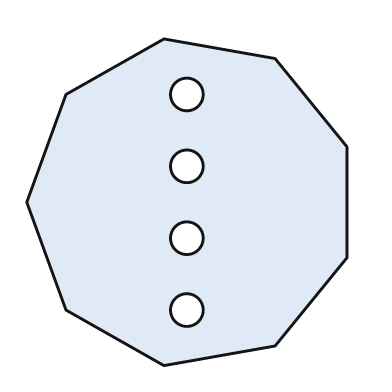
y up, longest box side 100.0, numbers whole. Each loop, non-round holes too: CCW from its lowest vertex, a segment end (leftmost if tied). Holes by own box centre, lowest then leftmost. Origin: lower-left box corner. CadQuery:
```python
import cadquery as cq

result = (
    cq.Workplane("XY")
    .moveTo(42.0, 0.0)
    .lineTo(76.0, 6.0)
    .lineTo(98.0, 33.0)
    .lineTo(98.0, 67.0)
    .lineTo(76.0, 94.0)
    .lineTo(42.0, 100.0)
    .lineTo(12.0, 83.0)
    .lineTo(0.0, 50.0)
    .lineTo(12.0, 17.0)
    .close()
    .moveTo(49.0, 17.0)
    .circle(5.0)
    .moveTo(49.0, 39.0)
    .circle(5.0)
    .moveTo(49.0, 61.0)
    .circle(5.0)
    .moveTo(49.0, 83.0)
    .circle(5.0)
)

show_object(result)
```